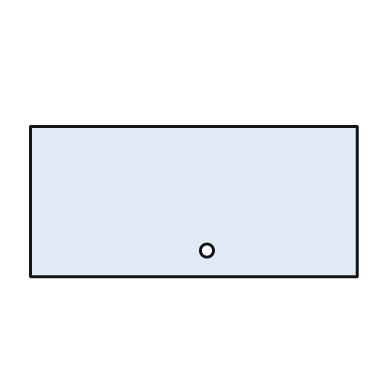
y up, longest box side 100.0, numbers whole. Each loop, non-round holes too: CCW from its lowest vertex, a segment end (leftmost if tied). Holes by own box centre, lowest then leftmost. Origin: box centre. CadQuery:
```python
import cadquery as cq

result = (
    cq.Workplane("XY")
    .moveTo(-50.0, -23.0)
    .lineTo(50.0, -23.0)
    .lineTo(50.0, 23.0)
    .lineTo(-50.0, 23.0)
    .close()
    .moveTo(4.0, -15.0)
    .circle(2.0)
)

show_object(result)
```